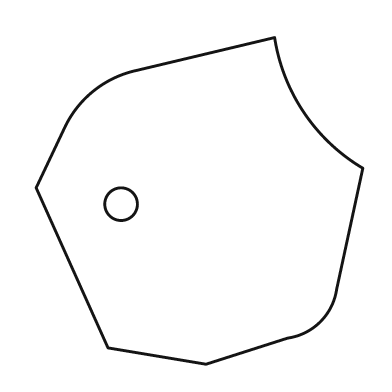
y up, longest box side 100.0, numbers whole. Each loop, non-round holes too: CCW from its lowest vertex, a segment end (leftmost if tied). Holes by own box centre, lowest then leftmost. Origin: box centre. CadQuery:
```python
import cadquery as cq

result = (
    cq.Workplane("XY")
    .moveTo(2.0, -50.0)
    .lineTo(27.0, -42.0)
    .threePointArc((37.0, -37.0), (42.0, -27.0))
    .lineTo(50.0, 10.0)
    .threePointArc((32.0, 27.0), (23.0, 50.0))
    .lineTo(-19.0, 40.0)
    .threePointArc((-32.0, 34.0), (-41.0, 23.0))
    .lineTo(-50.0, 4.0)
    .lineTo(-28.0, -45.0)
    .close()
    .moveTo(-24.0, -1.0)
    .circle(5.0)
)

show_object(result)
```